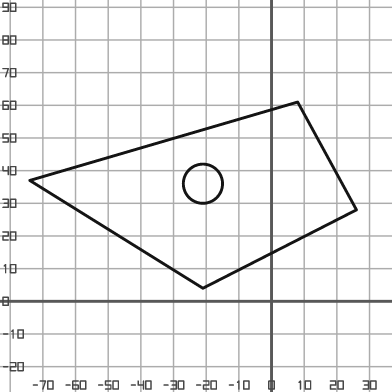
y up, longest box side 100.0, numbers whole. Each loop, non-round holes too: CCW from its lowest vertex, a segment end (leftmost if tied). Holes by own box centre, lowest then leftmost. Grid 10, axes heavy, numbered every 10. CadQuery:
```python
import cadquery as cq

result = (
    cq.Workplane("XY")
    .moveTo(-21.0, 4.0)
    .lineTo(26.0, 28.0)
    .lineTo(8.0, 61.0)
    .lineTo(-74.0, 37.0)
    .close()
    .moveTo(-21.0, 36.0)
    .circle(6.0)
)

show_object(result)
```